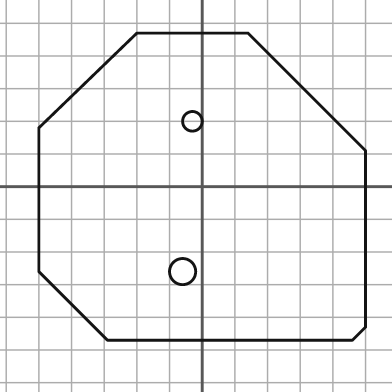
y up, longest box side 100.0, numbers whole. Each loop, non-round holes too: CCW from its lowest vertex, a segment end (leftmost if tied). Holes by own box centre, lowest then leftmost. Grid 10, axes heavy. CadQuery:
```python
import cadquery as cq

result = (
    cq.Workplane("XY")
    .moveTo(-29.0, -47.0)
    .lineTo(46.0, -47.0)
    .lineTo(50.0, -43.0)
    .lineTo(50.0, 11.0)
    .lineTo(14.0, 47.0)
    .lineTo(-20.0, 47.0)
    .lineTo(-50.0, 18.0)
    .lineTo(-50.0, -26.0)
    .close()
    .moveTo(-6.0, -26.0)
    .circle(4.0)
    .moveTo(-3.0, 20.0)
    .circle(3.0)
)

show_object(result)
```